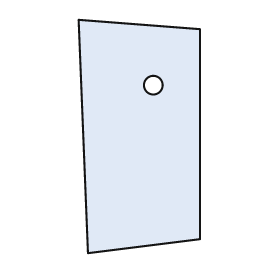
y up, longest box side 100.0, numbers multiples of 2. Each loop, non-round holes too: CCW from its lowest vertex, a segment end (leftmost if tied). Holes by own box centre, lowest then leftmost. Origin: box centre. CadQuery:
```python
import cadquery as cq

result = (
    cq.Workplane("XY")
    .moveTo(-22.0, -50.0)
    .lineTo(26.0, -44.0)
    .lineTo(26.0, 46.0)
    .lineTo(-26.0, 50.0)
    .close()
    .moveTo(6.0, 22.0)
    .circle(4.0)
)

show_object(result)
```